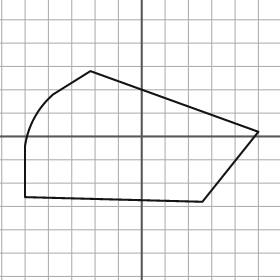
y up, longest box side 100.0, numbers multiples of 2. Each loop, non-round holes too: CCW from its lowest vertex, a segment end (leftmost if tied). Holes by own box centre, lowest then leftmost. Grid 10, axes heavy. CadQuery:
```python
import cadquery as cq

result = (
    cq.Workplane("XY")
    .moveTo(26.0, -28.0)
    .lineTo(50.0, 2.0)
    .lineTo(-22.0, 28.0)
    .lineTo(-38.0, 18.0)
    .threePointArc((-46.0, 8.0), (-50.0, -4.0))
    .lineTo(-50.0, -26.0)
    .close()
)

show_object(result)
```